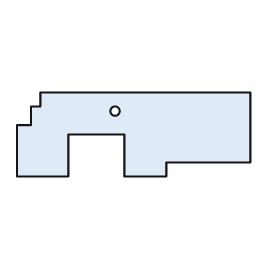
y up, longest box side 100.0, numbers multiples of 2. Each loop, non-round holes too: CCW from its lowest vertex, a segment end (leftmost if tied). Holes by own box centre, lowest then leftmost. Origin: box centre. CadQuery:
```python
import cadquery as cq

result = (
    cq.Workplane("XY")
    .moveTo(-50.0, -18.0)
    .lineTo(-28.0, -18.0)
    .lineTo(-28.0, 0.0)
    .lineTo(-4.0, 0.0)
    .lineTo(-4.0, -18.0)
    .lineTo(14.0, -18.0)
    .lineTo(14.0, -12.0)
    .lineTo(50.0, -12.0)
    .lineTo(50.0, 18.0)
    .lineTo(-40.0, 18.0)
    .lineTo(-40.0, 12.0)
    .lineTo(-44.0, 12.0)
    .lineTo(-44.0, 4.0)
    .lineTo(-50.0, 4.0)
    .close()
    .moveTo(-8.0, 10.0)
    .circle(2.0)
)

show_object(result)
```